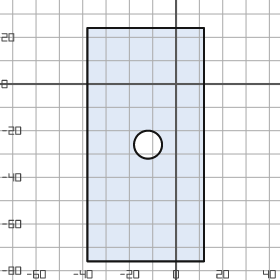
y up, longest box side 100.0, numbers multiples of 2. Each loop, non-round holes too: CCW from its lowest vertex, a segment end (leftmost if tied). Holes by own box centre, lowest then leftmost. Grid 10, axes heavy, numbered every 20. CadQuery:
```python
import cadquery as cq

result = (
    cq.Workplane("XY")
    .moveTo(-38.0, -76.0)
    .lineTo(12.0, -76.0)
    .lineTo(12.0, 24.0)
    .lineTo(-38.0, 24.0)
    .close()
    .moveTo(-12.0, -26.0)
    .circle(6.0)
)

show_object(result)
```